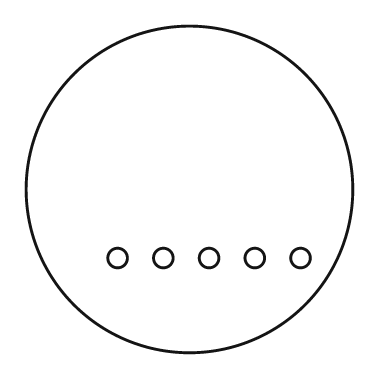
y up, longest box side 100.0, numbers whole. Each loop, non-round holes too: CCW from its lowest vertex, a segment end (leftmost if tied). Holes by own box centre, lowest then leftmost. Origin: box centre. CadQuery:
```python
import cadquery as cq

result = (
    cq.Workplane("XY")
    .moveTo(0.0, 0.0)
    .circle(50.0)
    .moveTo(-22.0, -21.0)
    .circle(3.0)
    .moveTo(-8.0, -21.0)
    .circle(3.0)
    .moveTo(6.0, -21.0)
    .circle(3.0)
    .moveTo(20.0, -21.0)
    .circle(3.0)
    .moveTo(34.0, -21.0)
    .circle(3.0)
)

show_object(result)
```